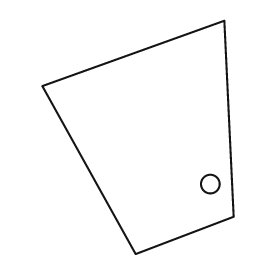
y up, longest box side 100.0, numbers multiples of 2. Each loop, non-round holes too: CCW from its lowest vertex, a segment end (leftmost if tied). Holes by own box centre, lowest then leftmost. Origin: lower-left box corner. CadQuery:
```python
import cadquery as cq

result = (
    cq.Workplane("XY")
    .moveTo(40.0, 0.0)
    .lineTo(82.0, 16.0)
    .lineTo(78.0, 100.0)
    .lineTo(0.0, 72.0)
    .close()
    .moveTo(72.0, 30.0)
    .circle(4.0)
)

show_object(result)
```